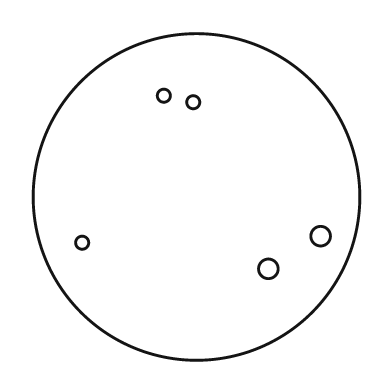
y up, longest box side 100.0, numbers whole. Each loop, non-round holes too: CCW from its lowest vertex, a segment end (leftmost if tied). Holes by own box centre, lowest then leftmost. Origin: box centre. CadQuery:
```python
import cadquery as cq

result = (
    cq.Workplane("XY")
    .moveTo(0.0, 0.0)
    .circle(50.0)
    .moveTo(22.0, -22.0)
    .circle(3.0)
    .moveTo(-35.0, -14.0)
    .circle(2.0)
    .moveTo(38.0, -12.0)
    .circle(3.0)
    .moveTo(-1.0, 29.0)
    .circle(2.0)
    .moveTo(-10.0, 31.0)
    .circle(2.0)
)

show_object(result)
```